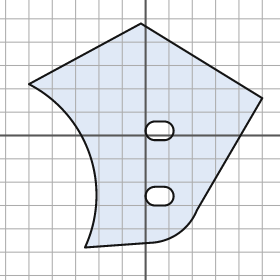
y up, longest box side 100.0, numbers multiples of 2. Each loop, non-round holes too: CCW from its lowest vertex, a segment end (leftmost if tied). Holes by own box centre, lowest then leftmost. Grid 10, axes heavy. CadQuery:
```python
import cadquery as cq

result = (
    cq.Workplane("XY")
    .moveTo(-26.0, -48.0)
    .lineTo(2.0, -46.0)
    .threePointArc((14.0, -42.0), (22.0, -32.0))
    .lineTo(50.0, 16.0)
    .lineTo(-2.0, 48.0)
    .lineTo(-50.0, 22.0)
    .threePointArc((-24.0, -8.0), (-26.0, -48.0))
    .close()
    .moveTo(4.0, -30.0)
    .lineTo(8.0, -30.0)
    .threePointArc((12.0, -26.0), (8.0, -22.0))
    .lineTo(4.0, -22.0)
    .threePointArc((0.0, -26.0), (4.0, -30.0))
    .close()
    .moveTo(4.0, -2.0)
    .lineTo(8.0, -2.0)
    .threePointArc((12.0, 2.0), (8.0, 6.0))
    .lineTo(4.0, 6.0)
    .threePointArc((0.0, 2.0), (4.0, -2.0))
    .close()
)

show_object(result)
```